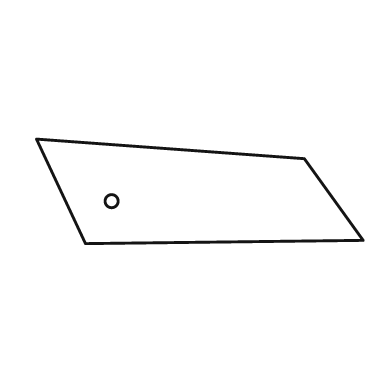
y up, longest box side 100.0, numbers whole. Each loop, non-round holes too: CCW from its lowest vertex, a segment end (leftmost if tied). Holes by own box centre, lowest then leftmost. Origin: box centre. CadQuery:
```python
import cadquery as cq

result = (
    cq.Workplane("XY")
    .moveTo(-35.0, -16.0)
    .lineTo(50.0, -15.0)
    .lineTo(32.0, 10.0)
    .lineTo(-50.0, 16.0)
    .close()
    .moveTo(-27.0, -3.0)
    .circle(2.0)
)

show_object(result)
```